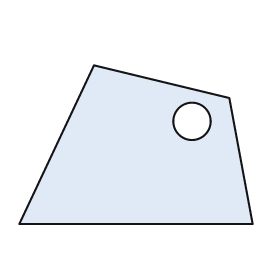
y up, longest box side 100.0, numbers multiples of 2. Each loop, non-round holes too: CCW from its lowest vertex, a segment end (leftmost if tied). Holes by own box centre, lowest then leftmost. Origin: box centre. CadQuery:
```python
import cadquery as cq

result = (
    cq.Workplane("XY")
    .moveTo(-50.0, -34.0)
    .lineTo(50.0, -34.0)
    .lineTo(40.0, 20.0)
    .lineTo(-18.0, 34.0)
    .close()
    .moveTo(24.0, 10.0)
    .circle(8.0)
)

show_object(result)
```